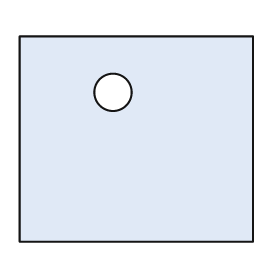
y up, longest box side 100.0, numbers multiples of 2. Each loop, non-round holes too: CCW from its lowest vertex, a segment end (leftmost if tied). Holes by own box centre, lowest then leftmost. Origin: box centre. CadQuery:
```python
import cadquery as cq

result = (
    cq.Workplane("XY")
    .moveTo(-50.0, -44.0)
    .lineTo(50.0, -44.0)
    .lineTo(50.0, 44.0)
    .lineTo(-50.0, 44.0)
    .close()
    .moveTo(-10.0, 20.0)
    .circle(8.0)
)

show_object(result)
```